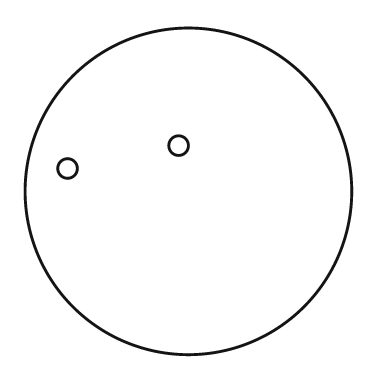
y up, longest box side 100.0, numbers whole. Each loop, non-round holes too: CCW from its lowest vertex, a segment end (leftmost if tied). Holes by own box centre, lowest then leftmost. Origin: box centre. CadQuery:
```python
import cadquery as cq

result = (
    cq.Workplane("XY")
    .moveTo(0.0, 0.0)
    .circle(50.0)
    .moveTo(-37.0, 7.0)
    .circle(3.0)
    .moveTo(-3.0, 14.0)
    .circle(3.0)
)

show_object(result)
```